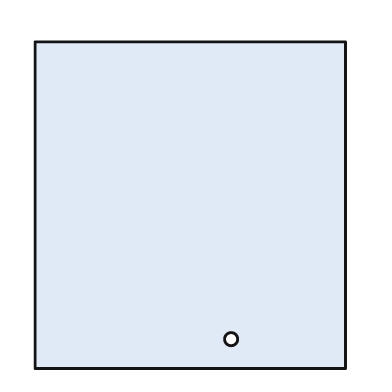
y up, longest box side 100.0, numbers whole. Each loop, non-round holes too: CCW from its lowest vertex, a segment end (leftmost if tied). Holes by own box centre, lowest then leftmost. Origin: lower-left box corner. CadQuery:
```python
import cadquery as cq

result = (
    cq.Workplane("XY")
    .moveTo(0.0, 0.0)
    .lineTo(95.0, 0.0)
    .lineTo(95.0, 100.0)
    .lineTo(0.0, 100.0)
    .close()
    .moveTo(60.0, 9.0)
    .circle(2.0)
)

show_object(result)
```